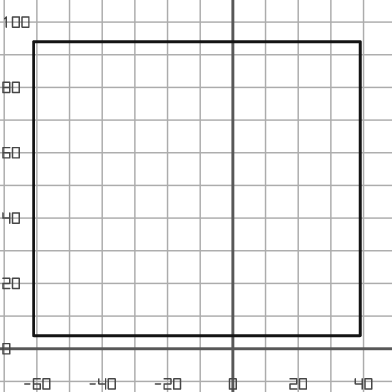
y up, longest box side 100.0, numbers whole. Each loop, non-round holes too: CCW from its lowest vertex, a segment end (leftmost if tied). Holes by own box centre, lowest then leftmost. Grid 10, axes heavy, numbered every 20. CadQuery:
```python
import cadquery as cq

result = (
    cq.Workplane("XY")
    .moveTo(-61.0, 4.0)
    .lineTo(39.0, 4.0)
    .lineTo(39.0, 94.0)
    .lineTo(-61.0, 94.0)
    .close()
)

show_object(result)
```